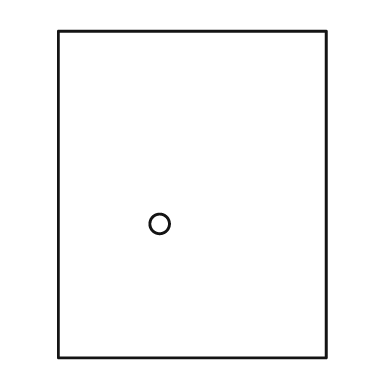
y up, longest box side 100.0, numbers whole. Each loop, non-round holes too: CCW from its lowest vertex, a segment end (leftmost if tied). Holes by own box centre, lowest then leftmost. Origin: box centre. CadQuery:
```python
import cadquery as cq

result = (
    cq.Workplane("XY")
    .moveTo(-41.0, -50.0)
    .lineTo(41.0, -50.0)
    .lineTo(41.0, 50.0)
    .lineTo(-41.0, 50.0)
    .close()
    .moveTo(-10.0, -9.0)
    .circle(3.0)
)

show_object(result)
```